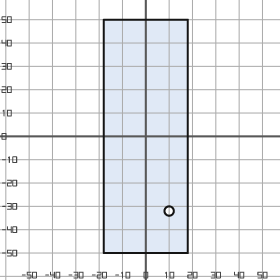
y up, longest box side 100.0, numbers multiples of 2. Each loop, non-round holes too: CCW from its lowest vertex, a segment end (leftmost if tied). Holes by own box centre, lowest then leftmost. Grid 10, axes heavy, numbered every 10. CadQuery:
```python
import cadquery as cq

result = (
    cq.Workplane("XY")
    .moveTo(-18.0, -50.0)
    .lineTo(18.0, -50.0)
    .lineTo(18.0, 50.0)
    .lineTo(-18.0, 50.0)
    .close()
    .moveTo(10.0, -32.0)
    .circle(2.0)
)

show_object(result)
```